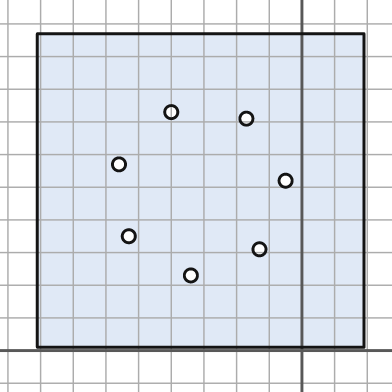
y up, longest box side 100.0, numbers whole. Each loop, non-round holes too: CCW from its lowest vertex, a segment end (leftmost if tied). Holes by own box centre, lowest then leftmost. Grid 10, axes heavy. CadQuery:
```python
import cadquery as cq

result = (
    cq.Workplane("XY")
    .moveTo(-81.0, 1.0)
    .lineTo(19.0, 1.0)
    .lineTo(19.0, 97.0)
    .lineTo(-81.0, 97.0)
    .close()
    .moveTo(-34.0, 23.0)
    .circle(2.0)
    .moveTo(-13.0, 31.0)
    .circle(2.0)
    .moveTo(-53.0, 35.0)
    .circle(2.0)
    .moveTo(-5.0, 52.0)
    .circle(2.0)
    .moveTo(-56.0, 57.0)
    .circle(2.0)
    .moveTo(-17.0, 71.0)
    .circle(2.0)
    .moveTo(-40.0, 73.0)
    .circle(2.0)
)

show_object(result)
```